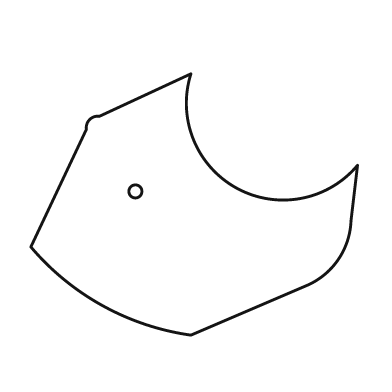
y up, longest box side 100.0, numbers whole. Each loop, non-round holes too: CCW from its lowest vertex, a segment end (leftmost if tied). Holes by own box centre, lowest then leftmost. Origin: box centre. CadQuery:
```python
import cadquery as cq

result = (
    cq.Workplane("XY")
    .moveTo(-1.0, -40.0)
    .lineTo(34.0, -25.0)
    .threePointArc((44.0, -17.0), (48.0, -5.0))
    .lineTo(50.0, 12.0)
    .threePointArc((13.0, 5.0), (-1.0, 40.0))
    .lineTo(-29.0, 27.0)
    .threePointArc((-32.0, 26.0), (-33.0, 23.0))
    .lineTo(-50.0, -13.0)
    .threePointArc((-28.0, -31.0), (-1.0, -40.0))
    .close()
    .moveTo(-18.0, 4.0)
    .circle(2.0)
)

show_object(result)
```